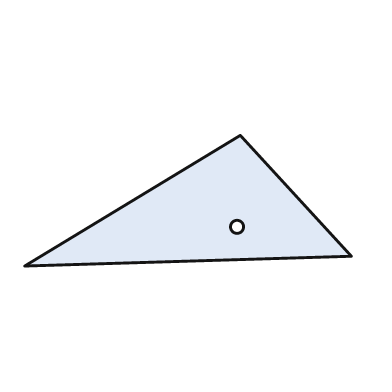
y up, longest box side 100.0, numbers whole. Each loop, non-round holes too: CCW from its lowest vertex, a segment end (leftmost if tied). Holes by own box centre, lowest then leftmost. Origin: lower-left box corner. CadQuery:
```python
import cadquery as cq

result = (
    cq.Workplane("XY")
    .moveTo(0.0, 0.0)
    .lineTo(100.0, 3.0)
    .lineTo(66.0, 40.0)
    .close()
    .moveTo(65.0, 12.0)
    .circle(2.0)
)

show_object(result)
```